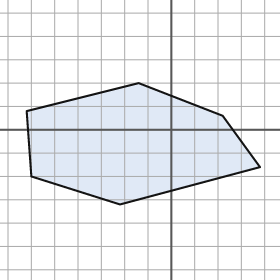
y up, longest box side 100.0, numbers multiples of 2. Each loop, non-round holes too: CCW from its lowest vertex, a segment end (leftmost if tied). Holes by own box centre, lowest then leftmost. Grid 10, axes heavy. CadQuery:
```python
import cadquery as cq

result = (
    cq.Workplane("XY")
    .moveTo(-22.0, -32.0)
    .lineTo(38.0, -16.0)
    .lineTo(22.0, 6.0)
    .lineTo(-14.0, 20.0)
    .lineTo(-62.0, 8.0)
    .lineTo(-60.0, -20.0)
    .close()
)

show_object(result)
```